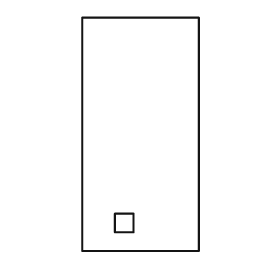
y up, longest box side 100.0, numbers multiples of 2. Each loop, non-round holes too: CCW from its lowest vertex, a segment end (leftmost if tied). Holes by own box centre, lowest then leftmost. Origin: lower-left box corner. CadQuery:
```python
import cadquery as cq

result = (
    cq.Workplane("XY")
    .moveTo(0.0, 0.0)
    .lineTo(50.0, 0.0)
    .lineTo(50.0, 100.0)
    .lineTo(0.0, 100.0)
    .close()
    .moveTo(14.0, 8.0)
    .lineTo(22.0, 8.0)
    .lineTo(22.0, 16.0)
    .lineTo(14.0, 16.0)
    .close()
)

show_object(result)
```